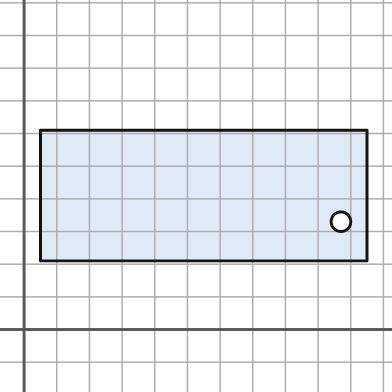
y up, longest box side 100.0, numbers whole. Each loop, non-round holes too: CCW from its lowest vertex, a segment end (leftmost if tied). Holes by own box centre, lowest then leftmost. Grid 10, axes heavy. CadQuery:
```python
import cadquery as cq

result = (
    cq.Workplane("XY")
    .moveTo(5.0, 21.0)
    .lineTo(105.0, 21.0)
    .lineTo(105.0, 61.0)
    .lineTo(5.0, 61.0)
    .close()
    .moveTo(97.0, 33.0)
    .circle(3.0)
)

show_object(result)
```